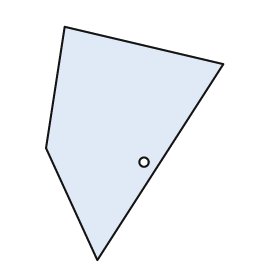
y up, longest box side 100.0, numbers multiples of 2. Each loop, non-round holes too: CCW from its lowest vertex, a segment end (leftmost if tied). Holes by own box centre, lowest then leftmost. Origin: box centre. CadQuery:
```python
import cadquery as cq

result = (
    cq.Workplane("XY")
    .moveTo(-16.0, -50.0)
    .lineTo(38.0, 34.0)
    .lineTo(-30.0, 50.0)
    .lineTo(-38.0, -2.0)
    .close()
    .moveTo(4.0, -8.0)
    .circle(2.0)
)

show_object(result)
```